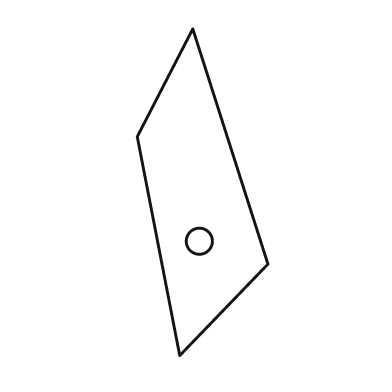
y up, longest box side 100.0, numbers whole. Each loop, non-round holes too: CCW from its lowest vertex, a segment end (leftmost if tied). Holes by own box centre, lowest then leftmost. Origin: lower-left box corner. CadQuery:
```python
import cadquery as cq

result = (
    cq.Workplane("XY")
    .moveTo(13.0, 0.0)
    .lineTo(40.0, 28.0)
    .lineTo(17.0, 100.0)
    .lineTo(0.0, 67.0)
    .close()
    .moveTo(19.0, 35.0)
    .circle(4.0)
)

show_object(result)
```